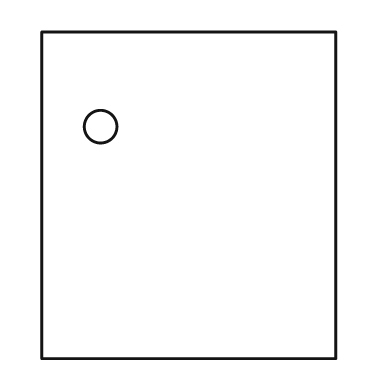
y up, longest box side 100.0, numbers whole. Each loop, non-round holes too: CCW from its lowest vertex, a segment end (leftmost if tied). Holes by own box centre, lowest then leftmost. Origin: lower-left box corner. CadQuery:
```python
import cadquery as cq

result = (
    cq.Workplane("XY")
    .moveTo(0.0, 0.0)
    .lineTo(90.0, 0.0)
    .lineTo(90.0, 100.0)
    .lineTo(0.0, 100.0)
    .close()
    .moveTo(18.0, 71.0)
    .circle(5.0)
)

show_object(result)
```